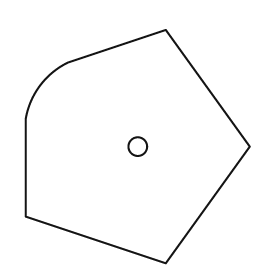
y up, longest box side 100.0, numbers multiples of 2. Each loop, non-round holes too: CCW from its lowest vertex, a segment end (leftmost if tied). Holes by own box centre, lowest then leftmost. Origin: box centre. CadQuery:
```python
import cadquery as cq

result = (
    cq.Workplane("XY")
    .moveTo(12.0, -50.0)
    .lineTo(48.0, 0.0)
    .lineTo(12.0, 50.0)
    .lineTo(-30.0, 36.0)
    .threePointArc((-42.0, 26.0), (-48.0, 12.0))
    .lineTo(-48.0, -30.0)
    .close()
    .moveTo(0.0, 0.0)
    .circle(4.0)
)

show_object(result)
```